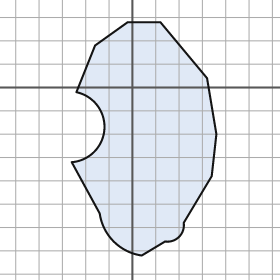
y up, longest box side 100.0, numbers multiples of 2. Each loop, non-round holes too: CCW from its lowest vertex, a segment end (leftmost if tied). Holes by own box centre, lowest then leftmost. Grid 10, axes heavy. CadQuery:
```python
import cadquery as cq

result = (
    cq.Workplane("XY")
    .moveTo(4.0, -72.0)
    .lineTo(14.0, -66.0)
    .threePointArc((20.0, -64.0), (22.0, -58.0))
    .lineTo(34.0, -38.0)
    .lineTo(36.0, -20.0)
    .lineTo(32.0, 4.0)
    .lineTo(12.0, 28.0)
    .lineTo(-2.0, 28.0)
    .lineTo(-16.0, 18.0)
    .lineTo(-24.0, -2.0)
    .threePointArc((-12.0, -18.0), (-26.0, -32.0))
    .lineTo(-14.0, -54.0)
    .threePointArc((-8.0, -66.0), (4.0, -72.0))
    .close()
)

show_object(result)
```